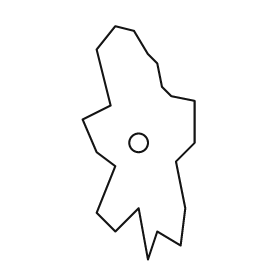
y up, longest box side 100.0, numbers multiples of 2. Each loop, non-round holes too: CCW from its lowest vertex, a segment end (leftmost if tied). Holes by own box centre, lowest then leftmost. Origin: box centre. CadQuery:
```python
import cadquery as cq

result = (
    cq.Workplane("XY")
    .moveTo(4.0, -50.0)
    .lineTo(8.0, -38.0)
    .lineTo(18.0, -44.0)
    .lineTo(20.0, -28.0)
    .lineTo(16.0, -8.0)
    .lineTo(24.0, 0.0)
    .lineTo(24.0, 18.0)
    .lineTo(14.0, 20.0)
    .lineTo(10.0, 24.0)
    .lineTo(8.0, 34.0)
    .lineTo(4.0, 38.0)
    .lineTo(-2.0, 48.0)
    .lineTo(-10.0, 50.0)
    .lineTo(-18.0, 40.0)
    .lineTo(-12.0, 16.0)
    .lineTo(-24.0, 10.0)
    .lineTo(-18.0, -4.0)
    .lineTo(-10.0, -10.0)
    .lineTo(-18.0, -30.0)
    .lineTo(-10.0, -38.0)
    .lineTo(0.0, -28.0)
    .close()
    .moveTo(0.0, 0.0)
    .circle(4.0)
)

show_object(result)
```